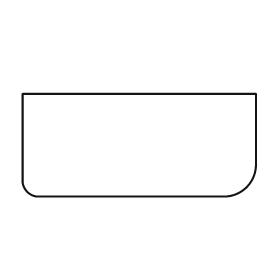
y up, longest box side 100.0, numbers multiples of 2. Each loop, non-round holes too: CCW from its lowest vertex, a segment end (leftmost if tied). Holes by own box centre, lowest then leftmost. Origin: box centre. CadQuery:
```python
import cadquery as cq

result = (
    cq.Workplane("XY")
    .moveTo(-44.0, -22.0)
    .lineTo(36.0, -22.0)
    .threePointArc((46.0, -18.0), (50.0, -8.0))
    .lineTo(50.0, 22.0)
    .lineTo(-50.0, 22.0)
    .lineTo(-50.0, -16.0)
    .threePointArc((-48.0, -20.0), (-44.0, -22.0))
    .close()
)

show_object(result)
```